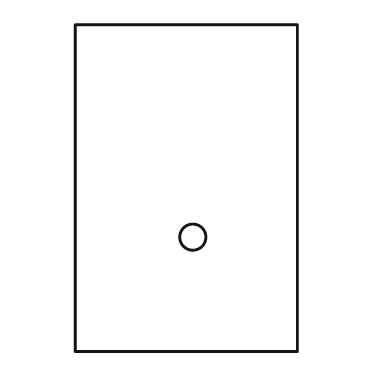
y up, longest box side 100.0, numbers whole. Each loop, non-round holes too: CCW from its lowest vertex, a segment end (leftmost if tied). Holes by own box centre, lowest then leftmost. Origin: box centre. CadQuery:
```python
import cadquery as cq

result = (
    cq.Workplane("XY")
    .moveTo(-34.0, -50.0)
    .lineTo(34.0, -50.0)
    .lineTo(34.0, 50.0)
    .lineTo(-34.0, 50.0)
    .close()
    .moveTo(2.0, -15.0)
    .circle(4.0)
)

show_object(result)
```